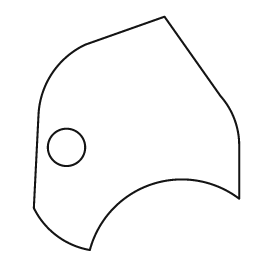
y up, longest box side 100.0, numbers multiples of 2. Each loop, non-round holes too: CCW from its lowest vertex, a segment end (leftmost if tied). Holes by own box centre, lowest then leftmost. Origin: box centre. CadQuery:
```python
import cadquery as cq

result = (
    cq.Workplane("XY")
    .moveTo(-20.0, -50.0)
    .threePointArc((6.0, -22.0), (44.0, -28.0))
    .lineTo(44.0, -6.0)
    .threePointArc((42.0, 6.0), (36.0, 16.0))
    .lineTo(12.0, 50.0)
    .lineTo(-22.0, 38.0)
    .threePointArc((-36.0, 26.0), (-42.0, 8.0))
    .lineTo(-44.0, -32.0)
    .threePointArc((-34.0, -44.0), (-20.0, -50.0))
    .close()
    .moveTo(-30.0, -6.0)
    .circle(8.0)
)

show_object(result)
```